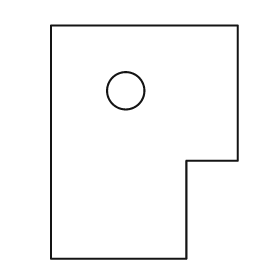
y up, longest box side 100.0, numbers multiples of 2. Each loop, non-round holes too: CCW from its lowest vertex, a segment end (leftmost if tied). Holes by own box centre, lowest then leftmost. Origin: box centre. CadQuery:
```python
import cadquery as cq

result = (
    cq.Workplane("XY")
    .moveTo(-40.0, -50.0)
    .lineTo(18.0, -50.0)
    .lineTo(18.0, -8.0)
    .lineTo(40.0, -8.0)
    .lineTo(40.0, 50.0)
    .lineTo(-40.0, 50.0)
    .close()
    .moveTo(-8.0, 22.0)
    .circle(8.0)
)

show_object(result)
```